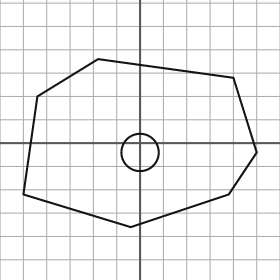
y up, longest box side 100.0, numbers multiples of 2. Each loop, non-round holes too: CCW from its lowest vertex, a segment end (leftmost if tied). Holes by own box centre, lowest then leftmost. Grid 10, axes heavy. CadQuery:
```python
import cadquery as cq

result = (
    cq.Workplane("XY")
    .moveTo(-4.0, -36.0)
    .lineTo(38.0, -22.0)
    .lineTo(50.0, -4.0)
    .lineTo(40.0, 28.0)
    .lineTo(-18.0, 36.0)
    .lineTo(-44.0, 20.0)
    .lineTo(-50.0, -22.0)
    .close()
    .moveTo(0.0, -4.0)
    .circle(8.0)
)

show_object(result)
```